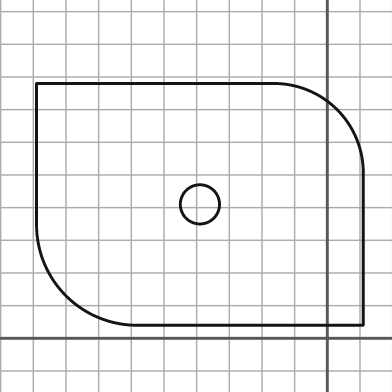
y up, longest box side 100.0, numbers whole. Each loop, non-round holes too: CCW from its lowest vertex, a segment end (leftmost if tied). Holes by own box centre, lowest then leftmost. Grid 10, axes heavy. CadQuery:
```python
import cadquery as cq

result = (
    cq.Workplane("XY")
    .moveTo(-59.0, 4.0)
    .lineTo(11.0, 4.0)
    .lineTo(11.0, 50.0)
    .threePointArc((3.0, 70.0), (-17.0, 78.0))
    .lineTo(-89.0, 78.0)
    .lineTo(-89.0, 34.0)
    .threePointArc((-80.0, 13.0), (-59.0, 4.0))
    .close()
    .moveTo(-39.0, 41.0)
    .circle(6.0)
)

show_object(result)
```